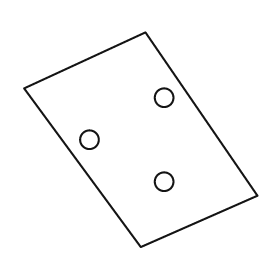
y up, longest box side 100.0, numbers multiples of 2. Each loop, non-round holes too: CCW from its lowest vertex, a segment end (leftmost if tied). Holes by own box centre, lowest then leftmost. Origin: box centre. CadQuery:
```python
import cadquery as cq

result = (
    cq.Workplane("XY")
    .moveTo(0.0, -46.0)
    .lineTo(50.0, -24.0)
    .lineTo(2.0, 46.0)
    .lineTo(-50.0, 22.0)
    .close()
    .moveTo(10.0, -18.0)
    .circle(4.0)
    .moveTo(-22.0, 0.0)
    .circle(4.0)
    .moveTo(10.0, 18.0)
    .circle(4.0)
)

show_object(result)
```